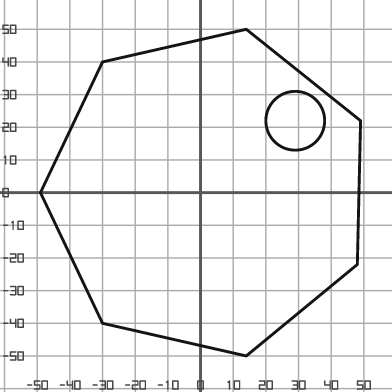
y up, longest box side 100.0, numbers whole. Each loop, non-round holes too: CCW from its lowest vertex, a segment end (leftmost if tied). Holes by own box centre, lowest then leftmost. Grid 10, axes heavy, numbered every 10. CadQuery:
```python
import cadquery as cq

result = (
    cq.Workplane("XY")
    .moveTo(14.0, -50.0)
    .lineTo(48.0, -22.0)
    .lineTo(49.0, 22.0)
    .lineTo(14.0, 50.0)
    .lineTo(-30.0, 40.0)
    .lineTo(-49.0, 0.0)
    .lineTo(-30.0, -40.0)
    .close()
    .moveTo(29.0, 22.0)
    .circle(9.0)
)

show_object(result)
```